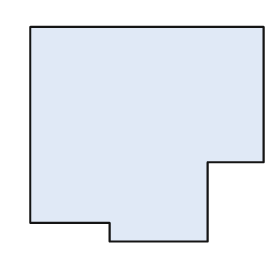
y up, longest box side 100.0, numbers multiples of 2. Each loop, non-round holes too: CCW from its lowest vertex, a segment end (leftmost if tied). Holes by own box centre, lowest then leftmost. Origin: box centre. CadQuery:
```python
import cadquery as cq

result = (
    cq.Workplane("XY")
    .moveTo(-16.0, -46.0)
    .lineTo(26.0, -46.0)
    .lineTo(26.0, -12.0)
    .lineTo(50.0, -12.0)
    .lineTo(50.0, 46.0)
    .lineTo(-50.0, 46.0)
    .lineTo(-50.0, -38.0)
    .lineTo(-16.0, -38.0)
    .close()
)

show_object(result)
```